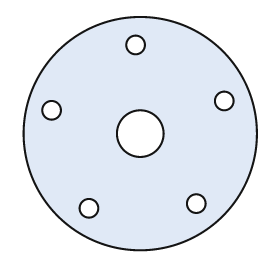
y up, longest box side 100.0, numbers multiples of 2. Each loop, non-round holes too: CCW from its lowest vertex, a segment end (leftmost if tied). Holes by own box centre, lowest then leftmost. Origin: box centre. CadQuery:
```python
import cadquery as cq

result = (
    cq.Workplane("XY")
    .moveTo(0.0, 0.0)
    .circle(50.0)
    .moveTo(-22.0, -32.0)
    .circle(4.0)
    .moveTo(24.0, -30.0)
    .circle(4.0)
    .moveTo(0.0, 0.0)
    .circle(10.0)
    .moveTo(-38.0, 10.0)
    .circle(4.0)
    .moveTo(36.0, 14.0)
    .circle(4.0)
    .moveTo(-2.0, 38.0)
    .circle(4.0)
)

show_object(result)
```